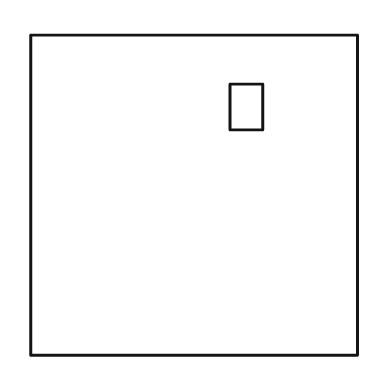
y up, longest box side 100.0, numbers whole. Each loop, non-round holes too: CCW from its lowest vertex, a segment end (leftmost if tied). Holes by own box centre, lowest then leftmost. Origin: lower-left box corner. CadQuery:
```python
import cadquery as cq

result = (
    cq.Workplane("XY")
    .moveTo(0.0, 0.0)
    .lineTo(100.0, 0.0)
    .lineTo(100.0, 98.0)
    .lineTo(0.0, 98.0)
    .close()
    .moveTo(61.0, 69.0)
    .lineTo(71.0, 69.0)
    .lineTo(71.0, 83.0)
    .lineTo(61.0, 83.0)
    .close()
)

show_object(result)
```